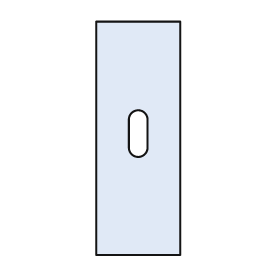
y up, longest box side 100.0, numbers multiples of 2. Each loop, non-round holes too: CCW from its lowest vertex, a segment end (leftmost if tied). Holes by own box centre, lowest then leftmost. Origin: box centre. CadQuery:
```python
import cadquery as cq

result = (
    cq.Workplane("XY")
    .moveTo(-18.0, -50.0)
    .lineTo(18.0, -50.0)
    .lineTo(18.0, 50.0)
    .lineTo(-18.0, 50.0)
    .close()
    .moveTo(-4.0, -4.0)
    .threePointArc((0.0, -8.0), (4.0, -4.0))
    .lineTo(4.0, 8.0)
    .threePointArc((0.0, 12.0), (-4.0, 8.0))
    .close()
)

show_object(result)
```